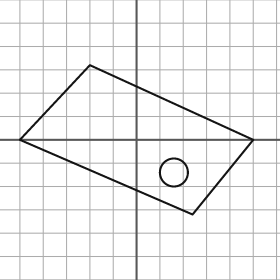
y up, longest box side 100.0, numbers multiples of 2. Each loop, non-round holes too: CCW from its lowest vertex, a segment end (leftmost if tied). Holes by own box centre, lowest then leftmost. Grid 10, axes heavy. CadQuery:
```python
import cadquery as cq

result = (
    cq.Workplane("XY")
    .moveTo(24.0, -32.0)
    .lineTo(50.0, 0.0)
    .lineTo(-20.0, 32.0)
    .lineTo(-50.0, 0.0)
    .close()
    .moveTo(16.0, -14.0)
    .circle(6.0)
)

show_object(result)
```